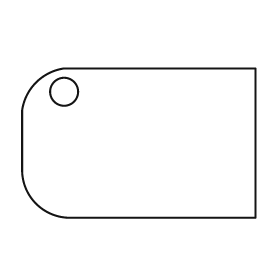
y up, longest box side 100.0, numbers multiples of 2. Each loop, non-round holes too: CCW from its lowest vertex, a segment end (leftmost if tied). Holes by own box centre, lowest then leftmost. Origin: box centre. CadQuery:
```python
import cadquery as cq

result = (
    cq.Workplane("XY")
    .moveTo(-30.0, -32.0)
    .lineTo(50.0, -32.0)
    .lineTo(50.0, 32.0)
    .lineTo(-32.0, 32.0)
    .threePointArc((-44.0, 26.0), (-50.0, 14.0))
    .lineTo(-50.0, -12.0)
    .threePointArc((-44.0, -26.0), (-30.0, -32.0))
    .close()
    .moveTo(-32.0, 22.0)
    .circle(6.0)
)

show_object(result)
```